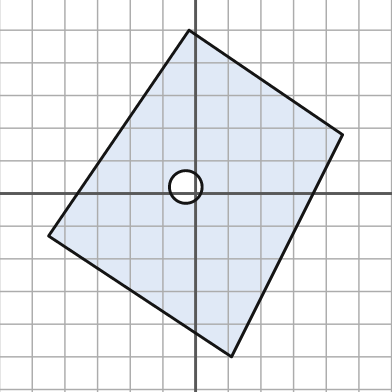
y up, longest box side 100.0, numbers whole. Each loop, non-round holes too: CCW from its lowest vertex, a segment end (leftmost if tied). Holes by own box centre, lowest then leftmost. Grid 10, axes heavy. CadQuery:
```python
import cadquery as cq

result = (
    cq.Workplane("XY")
    .moveTo(11.0, -50.0)
    .lineTo(45.0, 18.0)
    .lineTo(-2.0, 50.0)
    .lineTo(-45.0, -13.0)
    .close()
    .moveTo(-3.0, 2.0)
    .circle(5.0)
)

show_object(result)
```